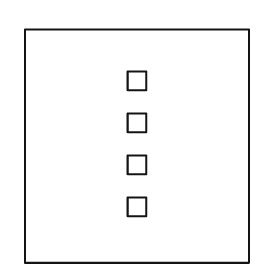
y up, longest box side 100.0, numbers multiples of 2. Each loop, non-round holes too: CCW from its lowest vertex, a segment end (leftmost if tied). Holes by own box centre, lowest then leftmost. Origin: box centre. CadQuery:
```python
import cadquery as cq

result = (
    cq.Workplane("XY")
    .moveTo(-48.0, -50.0)
    .lineTo(48.0, -50.0)
    .lineTo(48.0, 50.0)
    .lineTo(-48.0, 50.0)
    .close()
    .moveTo(-4.0, -30.0)
    .lineTo(4.0, -30.0)
    .lineTo(4.0, -22.0)
    .lineTo(-4.0, -22.0)
    .close()
    .moveTo(-4.0, -12.0)
    .lineTo(4.0, -12.0)
    .lineTo(4.0, -4.0)
    .lineTo(-4.0, -4.0)
    .close()
    .moveTo(-4.0, 6.0)
    .lineTo(4.0, 6.0)
    .lineTo(4.0, 14.0)
    .lineTo(-4.0, 14.0)
    .close()
    .moveTo(-4.0, 24.0)
    .lineTo(4.0, 24.0)
    .lineTo(4.0, 32.0)
    .lineTo(-4.0, 32.0)
    .close()
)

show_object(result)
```